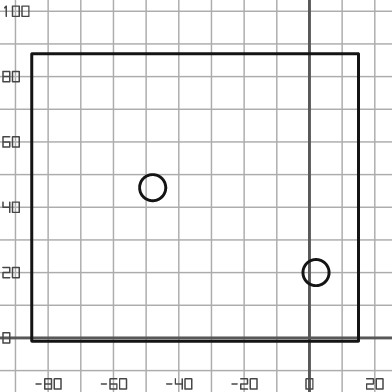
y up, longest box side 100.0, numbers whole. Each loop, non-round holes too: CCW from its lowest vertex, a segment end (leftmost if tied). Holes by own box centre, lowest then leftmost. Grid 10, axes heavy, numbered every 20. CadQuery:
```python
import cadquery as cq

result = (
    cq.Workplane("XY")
    .moveTo(-85.0, -1.0)
    .lineTo(15.0, -1.0)
    .lineTo(15.0, 87.0)
    .lineTo(-85.0, 87.0)
    .close()
    .moveTo(2.0, 20.0)
    .circle(4.0)
    .moveTo(-48.0, 46.0)
    .circle(4.0)
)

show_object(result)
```